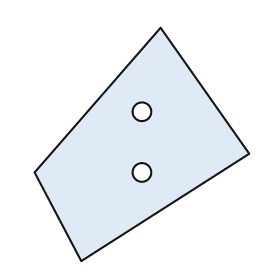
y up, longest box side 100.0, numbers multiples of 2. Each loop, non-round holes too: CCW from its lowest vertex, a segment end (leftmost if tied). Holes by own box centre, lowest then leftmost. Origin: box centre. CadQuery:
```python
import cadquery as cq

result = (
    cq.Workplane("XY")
    .moveTo(-26.0, -50.0)
    .lineTo(46.0, -4.0)
    .lineTo(8.0, 50.0)
    .lineTo(-46.0, -12.0)
    .close()
    .moveTo(0.0, -12.0)
    .circle(4.0)
    .moveTo(0.0, 14.0)
    .circle(4.0)
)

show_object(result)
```